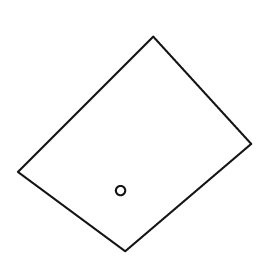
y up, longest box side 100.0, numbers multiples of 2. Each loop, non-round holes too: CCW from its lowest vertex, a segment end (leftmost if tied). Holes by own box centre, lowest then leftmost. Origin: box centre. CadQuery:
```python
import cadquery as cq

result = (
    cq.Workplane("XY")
    .moveTo(-4.0, -46.0)
    .lineTo(50.0, 0.0)
    .lineTo(8.0, 46.0)
    .lineTo(-50.0, -12.0)
    .close()
    .moveTo(-6.0, -20.0)
    .circle(2.0)
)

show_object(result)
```